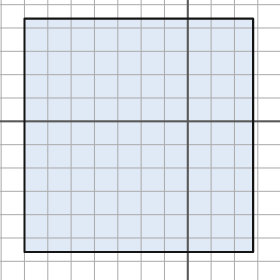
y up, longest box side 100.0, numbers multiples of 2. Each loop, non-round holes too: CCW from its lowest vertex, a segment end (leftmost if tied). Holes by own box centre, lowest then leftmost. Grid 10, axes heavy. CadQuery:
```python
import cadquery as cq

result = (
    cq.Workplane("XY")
    .moveTo(-70.0, -56.0)
    .lineTo(28.0, -56.0)
    .lineTo(28.0, 44.0)
    .lineTo(-70.0, 44.0)
    .close()
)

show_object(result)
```